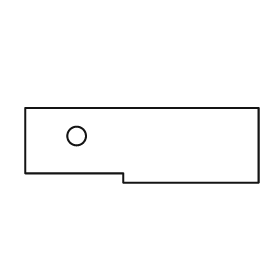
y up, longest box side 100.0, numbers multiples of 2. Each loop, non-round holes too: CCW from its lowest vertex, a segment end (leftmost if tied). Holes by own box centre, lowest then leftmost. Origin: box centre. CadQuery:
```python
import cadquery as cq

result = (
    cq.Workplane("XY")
    .moveTo(-8.0, -16.0)
    .lineTo(50.0, -16.0)
    .lineTo(50.0, 16.0)
    .lineTo(-50.0, 16.0)
    .lineTo(-50.0, -12.0)
    .lineTo(-8.0, -12.0)
    .close()
    .moveTo(-28.0, 4.0)
    .circle(4.0)
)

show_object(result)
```